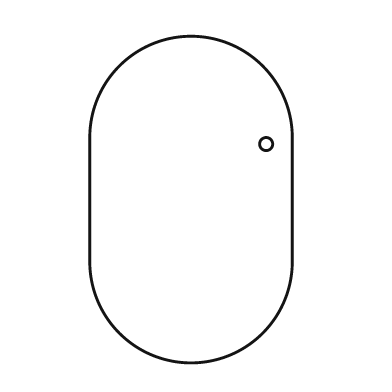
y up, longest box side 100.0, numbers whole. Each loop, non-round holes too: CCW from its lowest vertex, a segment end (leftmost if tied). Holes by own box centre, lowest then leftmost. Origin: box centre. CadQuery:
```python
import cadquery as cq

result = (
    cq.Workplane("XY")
    .moveTo(-31.0, -19.0)
    .threePointArc((0.0, -50.0), (31.0, -19.0))
    .lineTo(31.0, 19.0)
    .threePointArc((0.0, 50.0), (-31.0, 19.0))
    .close()
    .moveTo(23.0, 17.0)
    .circle(2.0)
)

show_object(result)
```